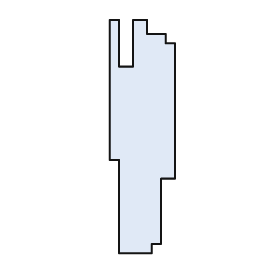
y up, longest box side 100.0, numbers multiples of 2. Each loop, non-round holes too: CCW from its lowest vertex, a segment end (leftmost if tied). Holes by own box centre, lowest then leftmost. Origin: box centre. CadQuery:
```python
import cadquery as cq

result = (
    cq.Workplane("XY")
    .moveTo(-10.0, -50.0)
    .lineTo(4.0, -50.0)
    .lineTo(4.0, -46.0)
    .lineTo(8.0, -46.0)
    .lineTo(8.0, -18.0)
    .lineTo(14.0, -18.0)
    .lineTo(14.0, 40.0)
    .lineTo(10.0, 40.0)
    .lineTo(10.0, 44.0)
    .lineTo(2.0, 44.0)
    .lineTo(2.0, 50.0)
    .lineTo(-4.0, 50.0)
    .lineTo(-4.0, 30.0)
    .lineTo(-10.0, 30.0)
    .lineTo(-10.0, 50.0)
    .lineTo(-14.0, 50.0)
    .lineTo(-14.0, -10.0)
    .lineTo(-10.0, -10.0)
    .close()
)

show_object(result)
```